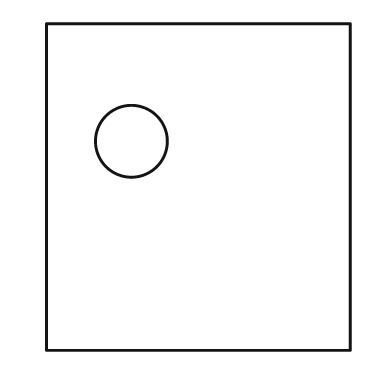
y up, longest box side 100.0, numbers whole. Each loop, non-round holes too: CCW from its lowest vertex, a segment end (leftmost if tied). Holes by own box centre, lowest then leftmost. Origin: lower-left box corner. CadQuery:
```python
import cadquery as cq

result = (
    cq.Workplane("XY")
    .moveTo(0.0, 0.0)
    .lineTo(93.0, 0.0)
    .lineTo(93.0, 100.0)
    .lineTo(0.0, 100.0)
    .close()
    .moveTo(26.0, 64.0)
    .circle(11.0)
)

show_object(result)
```